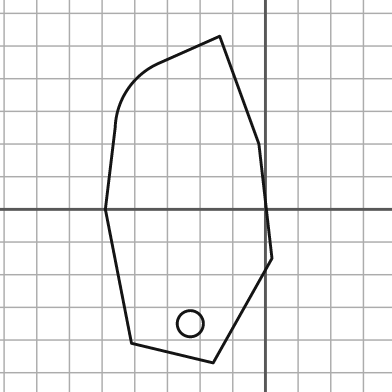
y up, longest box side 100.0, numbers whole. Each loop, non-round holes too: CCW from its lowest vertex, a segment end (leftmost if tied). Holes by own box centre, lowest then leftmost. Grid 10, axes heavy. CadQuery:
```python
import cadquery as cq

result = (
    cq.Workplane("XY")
    .moveTo(-16.0, -47.0)
    .lineTo(2.0, -15.0)
    .lineTo(-2.0, 20.0)
    .lineTo(-14.0, 53.0)
    .lineTo(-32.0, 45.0)
    .threePointArc((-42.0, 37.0), (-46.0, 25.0))
    .lineTo(-49.0, 0.0)
    .lineTo(-41.0, -41.0)
    .close()
    .moveTo(-23.0, -35.0)
    .circle(4.0)
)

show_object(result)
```